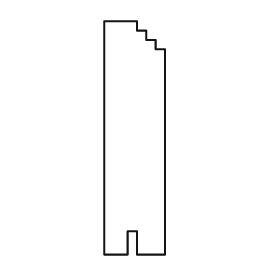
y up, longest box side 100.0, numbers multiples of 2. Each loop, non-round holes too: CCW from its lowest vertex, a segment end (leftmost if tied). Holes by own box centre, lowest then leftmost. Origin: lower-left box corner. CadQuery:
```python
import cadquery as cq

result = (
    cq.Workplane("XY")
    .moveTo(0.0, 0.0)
    .lineTo(10.0, 0.0)
    .lineTo(10.0, 10.0)
    .lineTo(14.0, 10.0)
    .lineTo(14.0, 0.0)
    .lineTo(26.0, 0.0)
    .lineTo(26.0, 88.0)
    .lineTo(22.0, 88.0)
    .lineTo(22.0, 92.0)
    .lineTo(18.0, 92.0)
    .lineTo(18.0, 96.0)
    .lineTo(14.0, 96.0)
    .lineTo(14.0, 100.0)
    .lineTo(0.0, 100.0)
    .close()
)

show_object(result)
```